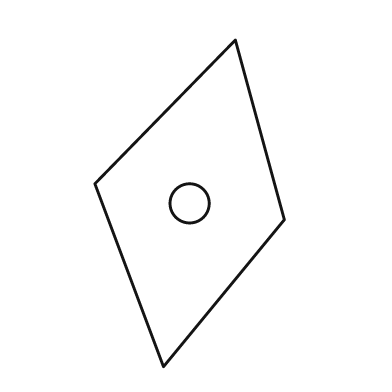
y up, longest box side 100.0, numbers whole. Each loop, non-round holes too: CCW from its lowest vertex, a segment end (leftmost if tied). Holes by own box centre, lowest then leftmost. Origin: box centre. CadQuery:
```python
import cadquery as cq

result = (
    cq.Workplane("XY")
    .moveTo(-8.0, -50.0)
    .lineTo(29.0, -5.0)
    .lineTo(14.0, 50.0)
    .lineTo(-29.0, 6.0)
    .close()
    .moveTo(0.0, 0.0)
    .circle(6.0)
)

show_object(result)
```